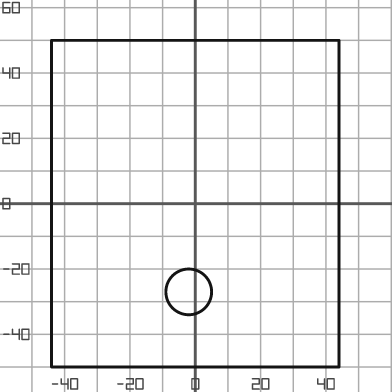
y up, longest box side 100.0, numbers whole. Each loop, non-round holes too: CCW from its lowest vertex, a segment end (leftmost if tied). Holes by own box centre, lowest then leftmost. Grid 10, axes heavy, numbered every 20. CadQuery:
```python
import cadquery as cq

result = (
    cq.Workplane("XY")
    .moveTo(-44.0, -50.0)
    .lineTo(44.0, -50.0)
    .lineTo(44.0, 50.0)
    .lineTo(-44.0, 50.0)
    .close()
    .moveTo(-2.0, -27.0)
    .circle(7.0)
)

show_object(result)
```